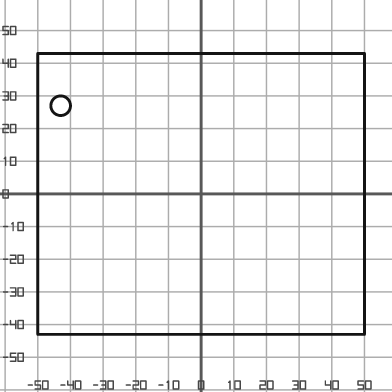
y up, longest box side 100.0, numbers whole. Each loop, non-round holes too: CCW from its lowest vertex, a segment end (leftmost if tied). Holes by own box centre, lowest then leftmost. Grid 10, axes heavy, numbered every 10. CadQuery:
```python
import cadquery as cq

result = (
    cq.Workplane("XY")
    .moveTo(-50.0, -43.0)
    .lineTo(50.0, -43.0)
    .lineTo(50.0, 43.0)
    .lineTo(-50.0, 43.0)
    .close()
    .moveTo(-43.0, 27.0)
    .circle(3.0)
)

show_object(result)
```